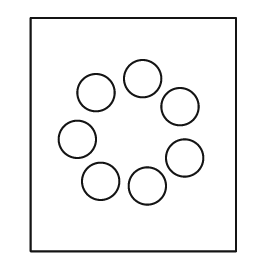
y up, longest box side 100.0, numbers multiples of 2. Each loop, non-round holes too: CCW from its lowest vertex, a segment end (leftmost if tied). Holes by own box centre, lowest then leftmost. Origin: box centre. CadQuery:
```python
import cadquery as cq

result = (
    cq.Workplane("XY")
    .moveTo(-44.0, -50.0)
    .lineTo(44.0, -50.0)
    .lineTo(44.0, 50.0)
    .lineTo(-44.0, 50.0)
    .close()
    .moveTo(6.0, -22.0)
    .circle(8.0)
    .moveTo(-14.0, -20.0)
    .circle(8.0)
    .moveTo(22.0, -10.0)
    .circle(8.0)
    .moveTo(-24.0, -2.0)
    .circle(8.0)
    .moveTo(20.0, 12.0)
    .circle(8.0)
    .moveTo(-16.0, 18.0)
    .circle(8.0)
    .moveTo(4.0, 24.0)
    .circle(8.0)
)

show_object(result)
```